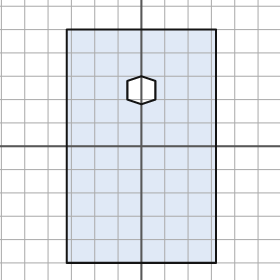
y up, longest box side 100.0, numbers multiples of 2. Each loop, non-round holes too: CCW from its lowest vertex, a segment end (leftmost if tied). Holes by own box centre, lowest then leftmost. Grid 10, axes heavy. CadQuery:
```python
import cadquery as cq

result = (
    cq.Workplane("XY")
    .moveTo(-32.0, -50.0)
    .lineTo(32.0, -50.0)
    .lineTo(32.0, 50.0)
    .lineTo(-32.0, 50.0)
    .close()
    .moveTo(0.0, 18.0)
    .lineTo(6.0, 20.0)
    .lineTo(6.0, 28.0)
    .lineTo(0.0, 30.0)
    .lineTo(-6.0, 28.0)
    .lineTo(-6.0, 20.0)
    .close()
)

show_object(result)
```